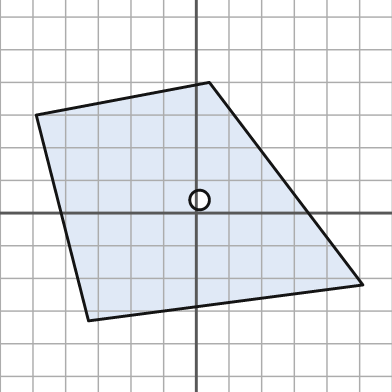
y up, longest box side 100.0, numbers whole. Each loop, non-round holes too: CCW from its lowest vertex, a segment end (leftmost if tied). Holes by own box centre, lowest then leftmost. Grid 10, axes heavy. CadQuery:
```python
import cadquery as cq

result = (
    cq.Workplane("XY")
    .moveTo(-33.0, -33.0)
    .lineTo(51.0, -22.0)
    .lineTo(4.0, 40.0)
    .lineTo(-49.0, 30.0)
    .close()
    .moveTo(1.0, 4.0)
    .circle(3.0)
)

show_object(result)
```